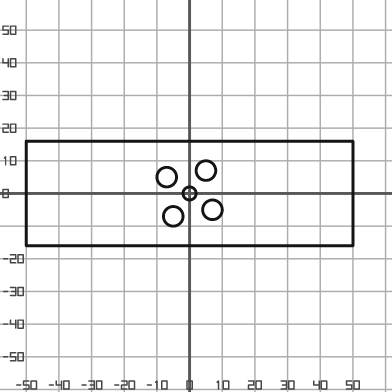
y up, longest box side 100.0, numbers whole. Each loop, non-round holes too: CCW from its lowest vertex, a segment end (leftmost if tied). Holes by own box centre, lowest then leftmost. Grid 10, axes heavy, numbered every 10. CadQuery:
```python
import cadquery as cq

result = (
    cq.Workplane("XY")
    .moveTo(-50.0, -16.0)
    .lineTo(50.0, -16.0)
    .lineTo(50.0, 16.0)
    .lineTo(-50.0, 16.0)
    .close()
    .moveTo(-5.0, -7.0)
    .circle(3.0)
    .moveTo(7.0, -5.0)
    .circle(3.0)
    .moveTo(0.0, 0.0)
    .circle(2.0)
    .moveTo(-7.0, 5.0)
    .circle(3.0)
    .moveTo(5.0, 7.0)
    .circle(3.0)
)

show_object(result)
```